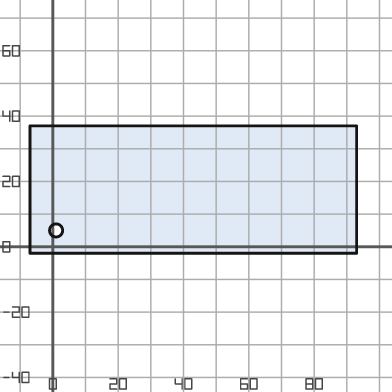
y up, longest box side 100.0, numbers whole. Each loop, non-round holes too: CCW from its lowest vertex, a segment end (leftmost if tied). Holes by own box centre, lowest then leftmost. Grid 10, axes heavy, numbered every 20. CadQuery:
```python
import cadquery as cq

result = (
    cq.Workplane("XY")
    .moveTo(-7.0, -2.0)
    .lineTo(93.0, -2.0)
    .lineTo(93.0, 37.0)
    .lineTo(-7.0, 37.0)
    .close()
    .moveTo(1.0, 5.0)
    .circle(2.0)
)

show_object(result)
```